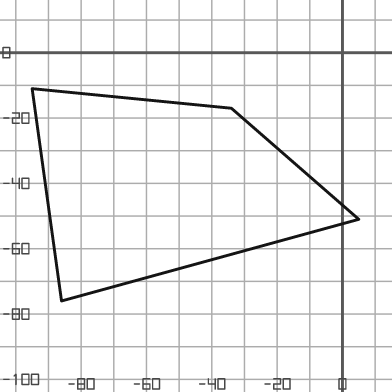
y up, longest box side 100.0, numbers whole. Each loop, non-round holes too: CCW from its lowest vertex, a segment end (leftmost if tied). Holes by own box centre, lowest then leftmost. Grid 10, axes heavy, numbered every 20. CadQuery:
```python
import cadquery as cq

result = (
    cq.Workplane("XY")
    .moveTo(-86.0, -76.0)
    .lineTo(5.0, -51.0)
    .lineTo(-34.0, -17.0)
    .lineTo(-95.0, -11.0)
    .close()
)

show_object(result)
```